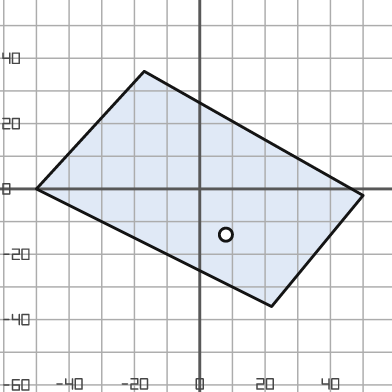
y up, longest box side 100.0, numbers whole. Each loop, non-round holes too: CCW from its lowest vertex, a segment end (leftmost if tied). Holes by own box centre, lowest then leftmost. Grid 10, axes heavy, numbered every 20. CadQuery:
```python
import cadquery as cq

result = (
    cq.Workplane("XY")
    .moveTo(22.0, -36.0)
    .lineTo(50.0, -2.0)
    .lineTo(-17.0, 36.0)
    .lineTo(-50.0, 0.0)
    .close()
    .moveTo(8.0, -14.0)
    .circle(2.0)
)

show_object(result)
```